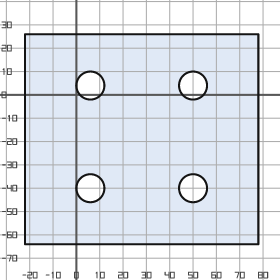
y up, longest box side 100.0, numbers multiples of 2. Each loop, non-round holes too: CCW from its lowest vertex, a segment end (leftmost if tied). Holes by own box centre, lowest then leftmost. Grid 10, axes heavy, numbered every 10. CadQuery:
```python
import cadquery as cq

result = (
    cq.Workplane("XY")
    .moveTo(-22.0, -64.0)
    .lineTo(78.0, -64.0)
    .lineTo(78.0, 26.0)
    .lineTo(-22.0, 26.0)
    .close()
    .moveTo(6.0, -40.0)
    .circle(6.0)
    .moveTo(50.0, -40.0)
    .circle(6.0)
    .moveTo(6.0, 4.0)
    .circle(6.0)
    .moveTo(50.0, 4.0)
    .circle(6.0)
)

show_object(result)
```